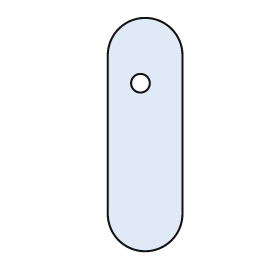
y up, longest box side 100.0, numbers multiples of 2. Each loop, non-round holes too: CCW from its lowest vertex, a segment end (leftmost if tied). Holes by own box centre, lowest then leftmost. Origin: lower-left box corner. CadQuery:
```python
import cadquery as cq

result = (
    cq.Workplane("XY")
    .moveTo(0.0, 16.0)
    .threePointArc((16.0, 0.0), (32.0, 16.0))
    .lineTo(32.0, 84.0)
    .threePointArc((16.0, 100.0), (0.0, 84.0))
    .close()
    .moveTo(14.0, 72.0)
    .circle(4.0)
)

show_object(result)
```